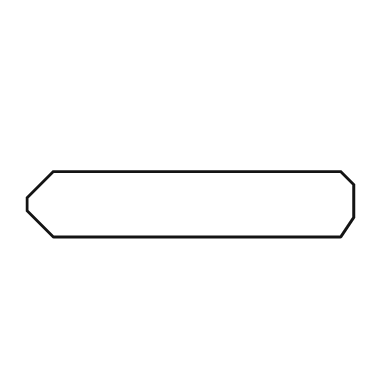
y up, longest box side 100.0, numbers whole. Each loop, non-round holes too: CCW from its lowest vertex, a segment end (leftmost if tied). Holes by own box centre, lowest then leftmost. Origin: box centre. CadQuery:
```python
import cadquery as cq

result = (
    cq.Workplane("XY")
    .moveTo(-42.0, -10.0)
    .lineTo(46.0, -10.0)
    .lineTo(50.0, -4.0)
    .lineTo(50.0, 6.0)
    .lineTo(46.0, 10.0)
    .lineTo(-42.0, 10.0)
    .lineTo(-50.0, 2.0)
    .lineTo(-50.0, -2.0)
    .close()
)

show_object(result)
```